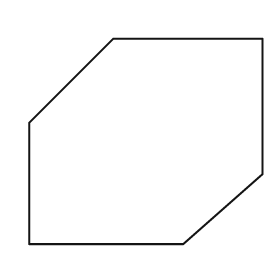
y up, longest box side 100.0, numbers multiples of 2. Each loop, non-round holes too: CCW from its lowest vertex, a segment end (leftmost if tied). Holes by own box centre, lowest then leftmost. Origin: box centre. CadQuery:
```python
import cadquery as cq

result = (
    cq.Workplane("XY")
    .moveTo(-50.0, -44.0)
    .lineTo(16.0, -44.0)
    .lineTo(50.0, -14.0)
    .lineTo(50.0, 44.0)
    .lineTo(-14.0, 44.0)
    .lineTo(-50.0, 8.0)
    .close()
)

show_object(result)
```